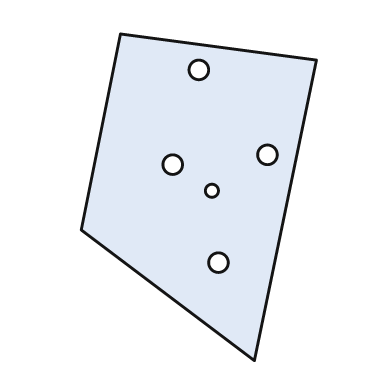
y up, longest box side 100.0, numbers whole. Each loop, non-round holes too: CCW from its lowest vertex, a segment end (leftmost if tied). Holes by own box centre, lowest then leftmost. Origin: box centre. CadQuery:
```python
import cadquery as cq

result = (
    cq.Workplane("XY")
    .moveTo(17.0, -50.0)
    .lineTo(36.0, 42.0)
    .lineTo(-24.0, 50.0)
    .lineTo(-36.0, -10.0)
    .close()
    .moveTo(6.0, -20.0)
    .circle(3.0)
    .moveTo(4.0, 2.0)
    .circle(2.0)
    .moveTo(-8.0, 10.0)
    .circle(3.0)
    .moveTo(21.0, 13.0)
    .circle(3.0)
    .moveTo(0.0, 39.0)
    .circle(3.0)
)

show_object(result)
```